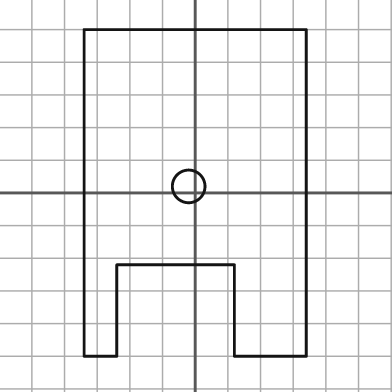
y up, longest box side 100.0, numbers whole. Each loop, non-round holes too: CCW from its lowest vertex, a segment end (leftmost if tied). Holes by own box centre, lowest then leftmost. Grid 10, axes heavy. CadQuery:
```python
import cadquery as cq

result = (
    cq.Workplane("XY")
    .moveTo(-34.0, -50.0)
    .lineTo(-24.0, -50.0)
    .lineTo(-24.0, -22.0)
    .lineTo(12.0, -22.0)
    .lineTo(12.0, -50.0)
    .lineTo(34.0, -50.0)
    .lineTo(34.0, 50.0)
    .lineTo(-34.0, 50.0)
    .close()
    .moveTo(-2.0, 2.0)
    .circle(5.0)
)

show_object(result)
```